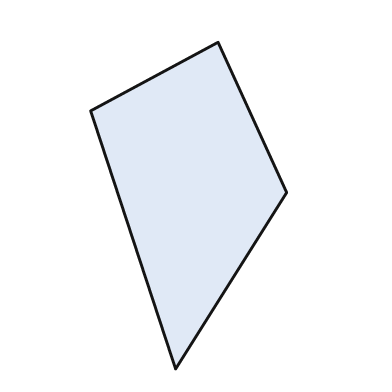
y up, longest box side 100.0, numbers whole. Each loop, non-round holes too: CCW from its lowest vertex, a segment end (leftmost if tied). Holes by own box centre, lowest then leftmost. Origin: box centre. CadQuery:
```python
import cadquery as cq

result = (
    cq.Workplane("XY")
    .moveTo(-4.0, -50.0)
    .lineTo(30.0, 4.0)
    .lineTo(9.0, 50.0)
    .lineTo(-30.0, 29.0)
    .close()
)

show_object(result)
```